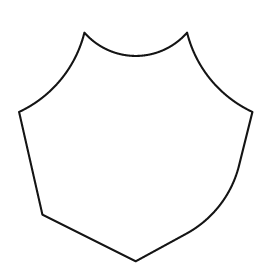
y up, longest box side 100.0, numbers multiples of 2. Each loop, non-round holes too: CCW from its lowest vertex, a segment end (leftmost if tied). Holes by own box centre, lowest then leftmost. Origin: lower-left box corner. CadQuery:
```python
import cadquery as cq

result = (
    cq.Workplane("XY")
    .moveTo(50.0, 0.0)
    .lineTo(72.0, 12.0)
    .threePointArc((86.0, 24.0), (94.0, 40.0))
    .lineTo(100.0, 64.0)
    .threePointArc((82.0, 78.0), (72.0, 98.0))
    .threePointArc((50.0, 88.0), (28.0, 98.0))
    .threePointArc((18.0, 78.0), (0.0, 64.0))
    .lineTo(10.0, 20.0)
    .close()
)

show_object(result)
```